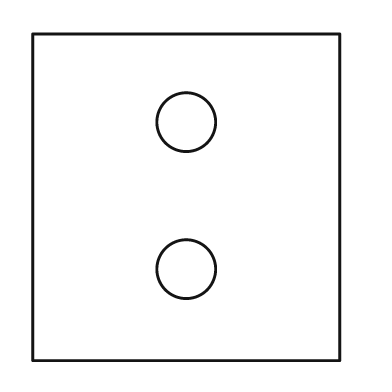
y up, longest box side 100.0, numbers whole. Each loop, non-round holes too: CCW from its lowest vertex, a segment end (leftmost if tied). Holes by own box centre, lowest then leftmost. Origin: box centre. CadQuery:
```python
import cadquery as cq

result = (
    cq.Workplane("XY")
    .moveTo(-47.0, -50.0)
    .lineTo(47.0, -50.0)
    .lineTo(47.0, 50.0)
    .lineTo(-47.0, 50.0)
    .close()
    .moveTo(0.0, -22.0)
    .circle(9.0)
    .moveTo(0.0, 23.0)
    .circle(9.0)
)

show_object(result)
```